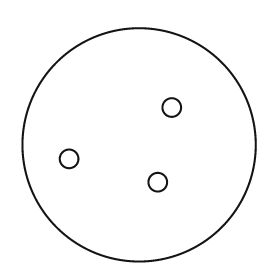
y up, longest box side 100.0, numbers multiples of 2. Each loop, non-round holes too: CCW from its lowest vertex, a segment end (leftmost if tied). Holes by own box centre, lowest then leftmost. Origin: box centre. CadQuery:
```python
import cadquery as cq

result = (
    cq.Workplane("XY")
    .moveTo(0.0, 0.0)
    .circle(50.0)
    .moveTo(8.0, -16.0)
    .circle(4.0)
    .moveTo(-30.0, -6.0)
    .circle(4.0)
    .moveTo(14.0, 16.0)
    .circle(4.0)
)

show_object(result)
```